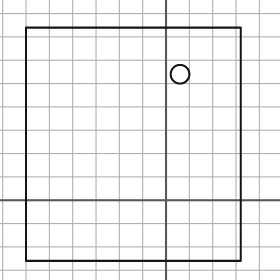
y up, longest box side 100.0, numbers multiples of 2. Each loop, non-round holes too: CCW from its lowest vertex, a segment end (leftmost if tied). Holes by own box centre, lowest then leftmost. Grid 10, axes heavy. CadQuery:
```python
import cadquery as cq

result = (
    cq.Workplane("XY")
    .moveTo(-60.0, -26.0)
    .lineTo(32.0, -26.0)
    .lineTo(32.0, 74.0)
    .lineTo(-60.0, 74.0)
    .close()
    .moveTo(6.0, 54.0)
    .circle(4.0)
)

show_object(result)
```